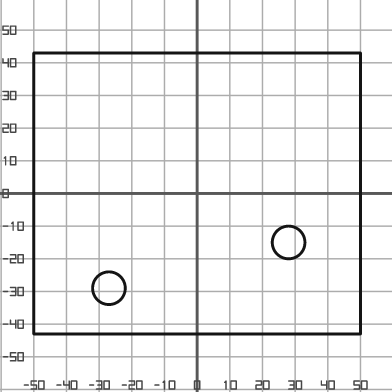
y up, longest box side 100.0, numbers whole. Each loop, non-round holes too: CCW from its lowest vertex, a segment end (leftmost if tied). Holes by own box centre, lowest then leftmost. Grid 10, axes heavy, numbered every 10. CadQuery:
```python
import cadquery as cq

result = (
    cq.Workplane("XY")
    .moveTo(-50.0, -43.0)
    .lineTo(50.0, -43.0)
    .lineTo(50.0, 43.0)
    .lineTo(-50.0, 43.0)
    .close()
    .moveTo(-27.0, -29.0)
    .circle(5.0)
    .moveTo(28.0, -15.0)
    .circle(5.0)
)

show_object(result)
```